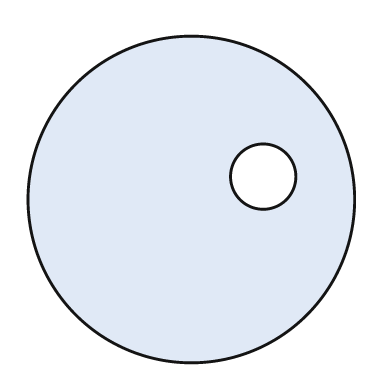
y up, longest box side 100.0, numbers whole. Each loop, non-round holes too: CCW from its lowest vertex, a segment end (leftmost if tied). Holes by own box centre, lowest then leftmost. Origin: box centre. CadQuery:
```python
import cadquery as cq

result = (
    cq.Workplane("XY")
    .moveTo(0.0, 0.0)
    .circle(50.0)
    .moveTo(22.0, 7.0)
    .circle(10.0)
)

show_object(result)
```